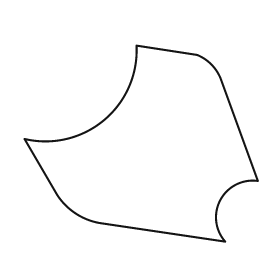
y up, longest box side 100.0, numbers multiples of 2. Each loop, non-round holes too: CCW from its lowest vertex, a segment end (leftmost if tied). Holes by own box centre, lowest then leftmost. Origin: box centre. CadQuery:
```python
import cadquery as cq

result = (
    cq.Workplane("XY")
    .moveTo(36.0, -42.0)
    .threePointArc((34.0, -24.0), (50.0, -16.0))
    .lineTo(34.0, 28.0)
    .threePointArc((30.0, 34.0), (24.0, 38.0))
    .lineTo(-2.0, 42.0)
    .threePointArc((-16.0, 10.0), (-50.0, 2.0))
    .lineTo(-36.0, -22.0)
    .threePointArc((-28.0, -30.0), (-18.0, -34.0))
    .close()
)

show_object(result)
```